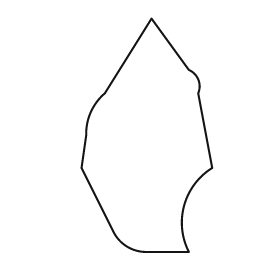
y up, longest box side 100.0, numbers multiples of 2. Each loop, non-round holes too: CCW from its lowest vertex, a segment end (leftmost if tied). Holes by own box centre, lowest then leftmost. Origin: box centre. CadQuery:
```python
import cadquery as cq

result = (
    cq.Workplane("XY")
    .moveTo(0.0, -50.0)
    .lineTo(18.0, -50.0)
    .threePointArc((16.0, -30.0), (28.0, -14.0))
    .lineTo(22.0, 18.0)
    .threePointArc((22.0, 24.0), (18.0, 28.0))
    .lineTo(2.0, 50.0)
    .lineTo(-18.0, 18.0)
    .threePointArc((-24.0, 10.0), (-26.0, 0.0))
    .lineTo(-28.0, -14.0)
    .lineTo(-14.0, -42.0)
    .threePointArc((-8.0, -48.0), (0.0, -50.0))
    .close()
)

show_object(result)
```